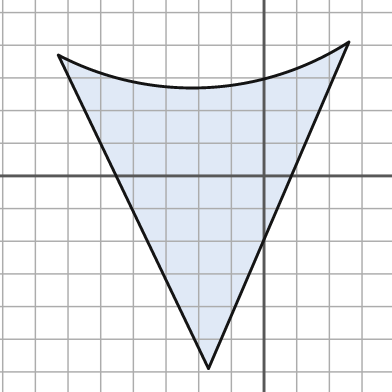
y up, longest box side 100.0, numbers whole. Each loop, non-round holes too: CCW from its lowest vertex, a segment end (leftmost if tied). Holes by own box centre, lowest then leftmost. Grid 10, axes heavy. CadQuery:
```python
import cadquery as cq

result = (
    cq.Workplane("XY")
    .moveTo(-17.0, -59.0)
    .lineTo(26.0, 41.0)
    .threePointArc((-18.0, 27.0), (-63.0, 37.0))
    .close()
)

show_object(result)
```